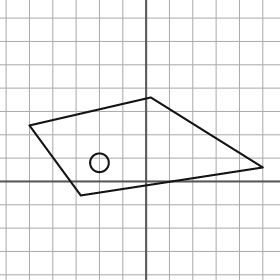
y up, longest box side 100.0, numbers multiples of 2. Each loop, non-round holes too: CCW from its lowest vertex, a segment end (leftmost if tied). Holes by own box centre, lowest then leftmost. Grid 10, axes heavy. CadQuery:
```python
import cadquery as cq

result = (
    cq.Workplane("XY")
    .moveTo(-28.0, -6.0)
    .lineTo(50.0, 6.0)
    .lineTo(2.0, 36.0)
    .lineTo(-50.0, 24.0)
    .close()
    .moveTo(-20.0, 8.0)
    .circle(4.0)
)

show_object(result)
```